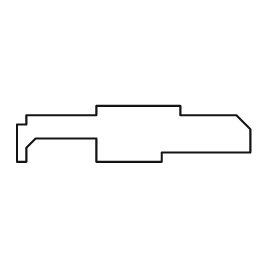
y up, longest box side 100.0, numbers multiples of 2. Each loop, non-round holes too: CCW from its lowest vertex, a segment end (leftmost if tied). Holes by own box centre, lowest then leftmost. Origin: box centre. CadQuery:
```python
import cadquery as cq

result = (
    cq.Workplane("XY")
    .moveTo(-50.0, -12.0)
    .lineTo(-46.0, -12.0)
    .lineTo(-46.0, -6.0)
    .lineTo(-42.0, -2.0)
    .lineTo(-16.0, -2.0)
    .lineTo(-16.0, -12.0)
    .lineTo(12.0, -12.0)
    .lineTo(12.0, -8.0)
    .lineTo(50.0, -8.0)
    .lineTo(50.0, 2.0)
    .lineTo(44.0, 8.0)
    .lineTo(20.0, 8.0)
    .lineTo(20.0, 12.0)
    .lineTo(-16.0, 12.0)
    .lineTo(-16.0, 8.0)
    .lineTo(-46.0, 8.0)
    .lineTo(-46.0, 4.0)
    .lineTo(-50.0, 4.0)
    .close()
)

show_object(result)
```